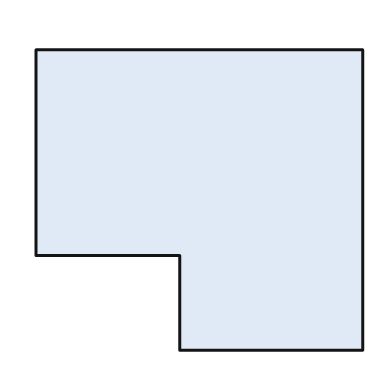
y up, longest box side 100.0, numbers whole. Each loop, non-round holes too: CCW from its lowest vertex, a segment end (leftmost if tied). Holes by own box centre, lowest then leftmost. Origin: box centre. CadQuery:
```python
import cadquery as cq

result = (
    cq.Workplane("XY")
    .moveTo(-6.0, -46.0)
    .lineTo(50.0, -46.0)
    .lineTo(50.0, 46.0)
    .lineTo(-50.0, 46.0)
    .lineTo(-50.0, -17.0)
    .lineTo(-6.0, -17.0)
    .close()
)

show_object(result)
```